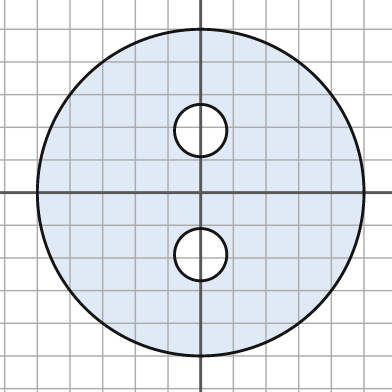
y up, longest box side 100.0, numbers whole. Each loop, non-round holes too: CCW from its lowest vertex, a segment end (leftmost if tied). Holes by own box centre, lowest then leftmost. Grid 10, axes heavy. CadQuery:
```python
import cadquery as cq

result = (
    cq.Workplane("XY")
    .moveTo(0.0, 0.0)
    .circle(50.0)
    .moveTo(0.0, -19.0)
    .circle(8.0)
    .moveTo(0.0, 19.0)
    .circle(8.0)
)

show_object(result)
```